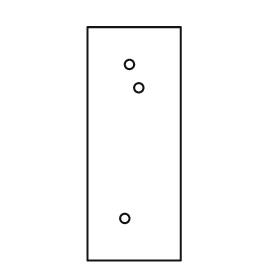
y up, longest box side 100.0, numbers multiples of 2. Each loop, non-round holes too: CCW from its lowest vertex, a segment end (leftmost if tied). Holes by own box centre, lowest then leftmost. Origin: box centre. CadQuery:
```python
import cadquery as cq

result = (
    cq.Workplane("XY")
    .moveTo(-20.0, -50.0)
    .lineTo(20.0, -50.0)
    .lineTo(20.0, 50.0)
    .lineTo(-20.0, 50.0)
    .close()
    .moveTo(-4.0, -32.0)
    .circle(2.0)
    .moveTo(2.0, 24.0)
    .circle(2.0)
    .moveTo(-2.0, 34.0)
    .circle(2.0)
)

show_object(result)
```